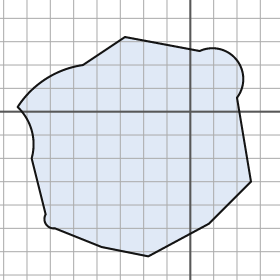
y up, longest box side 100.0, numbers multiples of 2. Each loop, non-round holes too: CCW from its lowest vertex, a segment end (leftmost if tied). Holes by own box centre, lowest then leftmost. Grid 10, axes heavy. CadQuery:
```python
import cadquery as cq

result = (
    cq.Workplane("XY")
    .moveTo(-18.0, -62.0)
    .lineTo(8.0, -48.0)
    .lineTo(26.0, -30.0)
    .lineTo(20.0, 6.0)
    .threePointArc((20.0, 22.0), (4.0, 26.0))
    .lineTo(-28.0, 32.0)
    .lineTo(-46.0, 20.0)
    .threePointArc((-62.0, 14.0), (-74.0, 2.0))
    .threePointArc((-68.0, -8.0), (-68.0, -20.0))
    .lineTo(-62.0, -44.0)
    .threePointArc((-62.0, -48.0), (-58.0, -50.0))
    .lineTo(-38.0, -58.0)
    .close()
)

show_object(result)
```